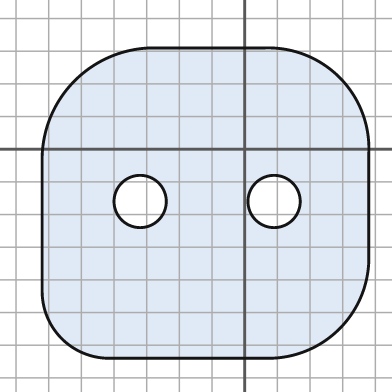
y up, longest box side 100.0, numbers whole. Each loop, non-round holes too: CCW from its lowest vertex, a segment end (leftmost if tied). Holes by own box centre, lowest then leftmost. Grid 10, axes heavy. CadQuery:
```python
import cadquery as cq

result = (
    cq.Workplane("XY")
    .moveTo(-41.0, -64.0)
    .lineTo(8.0, -64.0)
    .threePointArc((29.0, -55.0), (38.0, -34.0))
    .lineTo(38.0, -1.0)
    .threePointArc((29.0, 22.0), (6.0, 31.0))
    .lineTo(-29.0, 31.0)
    .threePointArc((-52.0, 21.0), (-62.0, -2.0))
    .lineTo(-62.0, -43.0)
    .threePointArc((-56.0, -58.0), (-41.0, -64.0))
    .close()
    .moveTo(-32.0, -16.0)
    .circle(8.0)
    .moveTo(9.0, -16.0)
    .circle(8.0)
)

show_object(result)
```